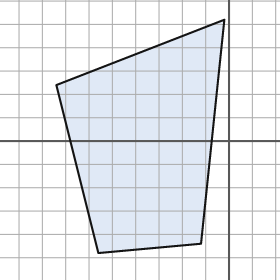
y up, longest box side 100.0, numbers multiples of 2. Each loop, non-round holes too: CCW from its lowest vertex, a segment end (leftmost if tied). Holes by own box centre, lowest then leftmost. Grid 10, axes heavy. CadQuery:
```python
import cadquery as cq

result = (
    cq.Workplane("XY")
    .moveTo(-56.0, -48.0)
    .lineTo(-12.0, -44.0)
    .lineTo(-2.0, 52.0)
    .lineTo(-74.0, 24.0)
    .close()
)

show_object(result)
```